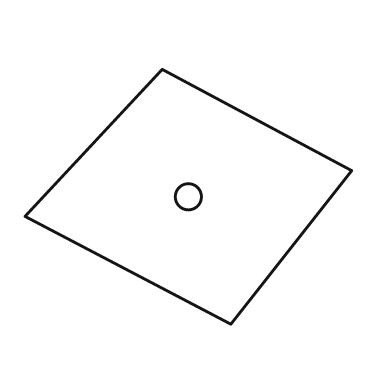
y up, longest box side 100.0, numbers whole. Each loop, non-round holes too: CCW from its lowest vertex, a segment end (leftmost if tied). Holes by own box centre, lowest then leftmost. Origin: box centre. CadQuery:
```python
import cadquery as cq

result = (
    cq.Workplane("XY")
    .moveTo(13.0, -39.0)
    .lineTo(50.0, 8.0)
    .lineTo(-8.0, 39.0)
    .lineTo(-50.0, -6.0)
    .close()
    .moveTo(0.0, 0.0)
    .circle(4.0)
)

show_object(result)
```